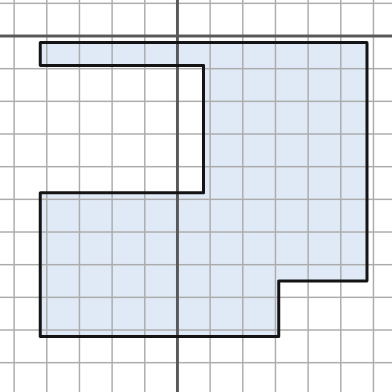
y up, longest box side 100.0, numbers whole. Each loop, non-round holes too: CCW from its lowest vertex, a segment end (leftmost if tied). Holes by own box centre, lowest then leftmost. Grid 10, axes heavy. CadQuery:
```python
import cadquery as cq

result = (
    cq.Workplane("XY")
    .moveTo(-42.0, -92.0)
    .lineTo(31.0, -92.0)
    .lineTo(31.0, -75.0)
    .lineTo(58.0, -75.0)
    .lineTo(58.0, -2.0)
    .lineTo(-42.0, -2.0)
    .lineTo(-42.0, -9.0)
    .lineTo(8.0, -9.0)
    .lineTo(8.0, -48.0)
    .lineTo(-42.0, -48.0)
    .close()
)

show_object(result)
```